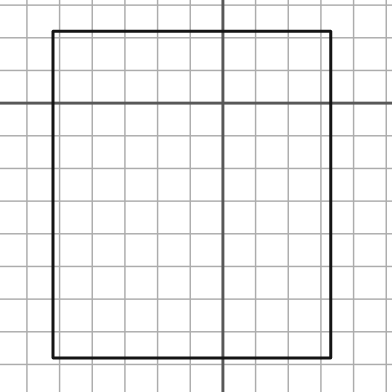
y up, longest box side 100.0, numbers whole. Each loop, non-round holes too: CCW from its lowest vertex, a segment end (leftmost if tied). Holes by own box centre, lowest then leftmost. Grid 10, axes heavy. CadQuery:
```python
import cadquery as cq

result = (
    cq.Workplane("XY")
    .moveTo(-52.0, -78.0)
    .lineTo(33.0, -78.0)
    .lineTo(33.0, 22.0)
    .lineTo(-52.0, 22.0)
    .close()
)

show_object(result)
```